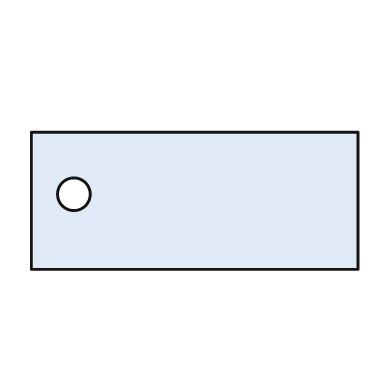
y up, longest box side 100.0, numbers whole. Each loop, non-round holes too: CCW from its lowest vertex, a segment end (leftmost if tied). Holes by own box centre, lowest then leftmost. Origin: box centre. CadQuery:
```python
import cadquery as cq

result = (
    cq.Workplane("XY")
    .moveTo(-50.0, -21.0)
    .lineTo(50.0, -21.0)
    .lineTo(50.0, 21.0)
    .lineTo(-50.0, 21.0)
    .close()
    .moveTo(-37.0, 2.0)
    .circle(5.0)
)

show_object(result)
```